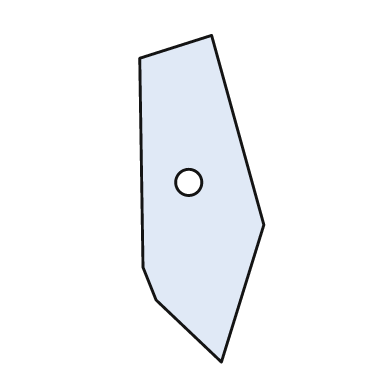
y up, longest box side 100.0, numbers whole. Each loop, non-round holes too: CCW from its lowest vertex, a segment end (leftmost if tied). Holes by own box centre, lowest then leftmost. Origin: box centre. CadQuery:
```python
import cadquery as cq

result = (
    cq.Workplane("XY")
    .moveTo(6.0, -50.0)
    .lineTo(19.0, -8.0)
    .lineTo(3.0, 50.0)
    .lineTo(-19.0, 43.0)
    .lineTo(-18.0, -21.0)
    .lineTo(-14.0, -31.0)
    .close()
    .moveTo(-4.0, 5.0)
    .circle(4.0)
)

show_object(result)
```